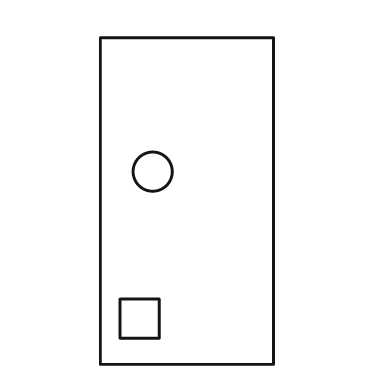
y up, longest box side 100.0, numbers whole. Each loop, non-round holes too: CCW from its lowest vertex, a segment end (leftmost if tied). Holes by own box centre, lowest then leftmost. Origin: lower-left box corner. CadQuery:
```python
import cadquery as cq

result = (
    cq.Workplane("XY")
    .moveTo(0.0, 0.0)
    .lineTo(53.0, 0.0)
    .lineTo(53.0, 100.0)
    .lineTo(0.0, 100.0)
    .close()
    .moveTo(6.0, 8.0)
    .lineTo(18.0, 8.0)
    .lineTo(18.0, 20.0)
    .lineTo(6.0, 20.0)
    .close()
    .moveTo(16.0, 59.0)
    .circle(6.0)
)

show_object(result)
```